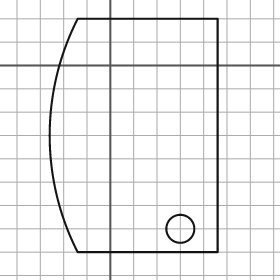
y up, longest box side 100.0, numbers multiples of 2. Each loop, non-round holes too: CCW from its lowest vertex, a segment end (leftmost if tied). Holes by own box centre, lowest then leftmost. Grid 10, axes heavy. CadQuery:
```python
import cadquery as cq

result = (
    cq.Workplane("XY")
    .moveTo(-14.0, -80.0)
    .lineTo(46.0, -80.0)
    .lineTo(46.0, 20.0)
    .lineTo(-14.0, 20.0)
    .threePointArc((-26.0, -30.0), (-14.0, -80.0))
    .close()
    .moveTo(30.0, -70.0)
    .circle(6.0)
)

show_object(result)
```